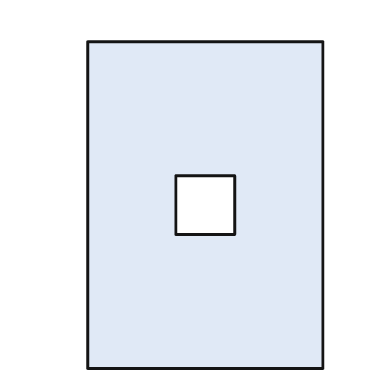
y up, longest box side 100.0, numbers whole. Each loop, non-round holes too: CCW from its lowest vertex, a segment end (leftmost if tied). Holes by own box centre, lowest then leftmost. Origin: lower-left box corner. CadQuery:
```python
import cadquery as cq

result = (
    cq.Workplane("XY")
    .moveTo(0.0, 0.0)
    .lineTo(72.0, 0.0)
    .lineTo(72.0, 100.0)
    .lineTo(0.0, 100.0)
    .close()
    .moveTo(27.0, 41.0)
    .lineTo(45.0, 41.0)
    .lineTo(45.0, 59.0)
    .lineTo(27.0, 59.0)
    .close()
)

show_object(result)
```